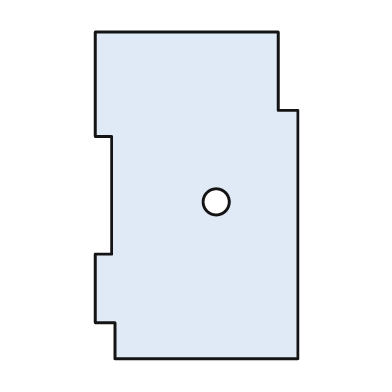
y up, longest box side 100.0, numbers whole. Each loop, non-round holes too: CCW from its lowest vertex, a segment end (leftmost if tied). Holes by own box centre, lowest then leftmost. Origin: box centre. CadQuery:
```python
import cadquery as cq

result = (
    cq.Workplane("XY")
    .moveTo(-25.0, -50.0)
    .lineTo(31.0, -50.0)
    .lineTo(31.0, 26.0)
    .lineTo(25.0, 26.0)
    .lineTo(25.0, 50.0)
    .lineTo(-31.0, 50.0)
    .lineTo(-31.0, 18.0)
    .lineTo(-26.0, 18.0)
    .lineTo(-26.0, -18.0)
    .lineTo(-31.0, -18.0)
    .lineTo(-31.0, -39.0)
    .lineTo(-25.0, -39.0)
    .close()
    .moveTo(6.0, -2.0)
    .circle(4.0)
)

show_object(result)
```